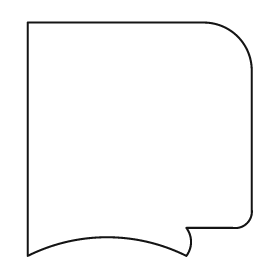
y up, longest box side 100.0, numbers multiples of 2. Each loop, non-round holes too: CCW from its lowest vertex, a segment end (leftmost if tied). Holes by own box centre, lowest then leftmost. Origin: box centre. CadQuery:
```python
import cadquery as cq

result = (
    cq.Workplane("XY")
    .moveTo(-48.0, -50.0)
    .threePointArc((-14.0, -42.0), (20.0, -50.0))
    .threePointArc((22.0, -44.0), (20.0, -38.0))
    .lineTo(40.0, -38.0)
    .threePointArc((46.0, -36.0), (48.0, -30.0))
    .lineTo(48.0, 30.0)
    .threePointArc((42.0, 44.0), (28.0, 50.0))
    .lineTo(-48.0, 50.0)
    .close()
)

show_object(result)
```